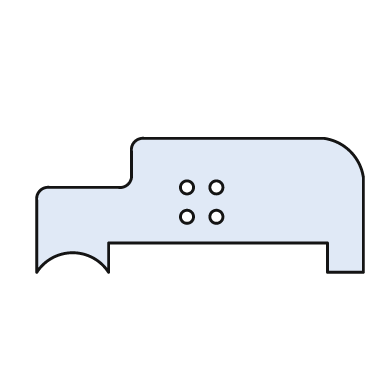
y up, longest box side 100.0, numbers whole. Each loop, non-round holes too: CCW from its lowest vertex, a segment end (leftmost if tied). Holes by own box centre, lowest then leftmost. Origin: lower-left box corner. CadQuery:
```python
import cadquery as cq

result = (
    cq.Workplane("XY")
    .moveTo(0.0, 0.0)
    .threePointArc((11.0, 6.0), (22.0, 0.0))
    .lineTo(22.0, 9.0)
    .lineTo(89.0, 9.0)
    .lineTo(89.0, 0.0)
    .lineTo(100.0, 0.0)
    .lineTo(100.0, 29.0)
    .threePointArc((96.0, 37.0), (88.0, 41.0))
    .lineTo(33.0, 41.0)
    .threePointArc((30.0, 40.0), (29.0, 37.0))
    .lineTo(29.0, 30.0)
    .threePointArc((28.0, 27.0), (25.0, 26.0))
    .lineTo(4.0, 26.0)
    .threePointArc((1.0, 25.0), (0.0, 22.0))
    .close()
    .moveTo(46.0, 17.0)
    .circle(2.0)
    .moveTo(55.0, 17.0)
    .circle(2.0)
    .moveTo(46.0, 26.0)
    .circle(2.0)
    .moveTo(55.0, 26.0)
    .circle(2.0)
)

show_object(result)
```